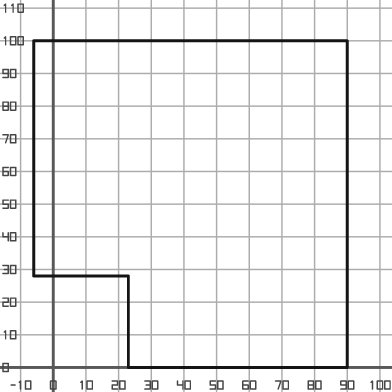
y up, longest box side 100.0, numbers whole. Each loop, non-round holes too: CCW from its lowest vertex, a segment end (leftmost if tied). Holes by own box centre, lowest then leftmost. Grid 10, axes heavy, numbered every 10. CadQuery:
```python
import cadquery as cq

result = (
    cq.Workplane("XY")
    .moveTo(23.0, 0.0)
    .lineTo(90.0, 0.0)
    .lineTo(90.0, 100.0)
    .lineTo(-6.0, 100.0)
    .lineTo(-6.0, 28.0)
    .lineTo(23.0, 28.0)
    .close()
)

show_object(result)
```